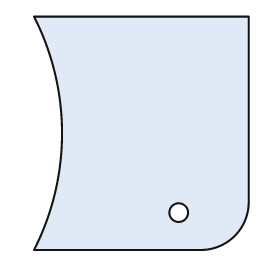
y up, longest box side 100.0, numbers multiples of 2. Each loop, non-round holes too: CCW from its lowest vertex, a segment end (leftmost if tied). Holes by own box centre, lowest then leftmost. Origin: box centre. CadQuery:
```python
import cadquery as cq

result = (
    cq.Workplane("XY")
    .moveTo(-46.0, -50.0)
    .lineTo(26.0, -50.0)
    .threePointArc((40.0, -44.0), (46.0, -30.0))
    .lineTo(46.0, 50.0)
    .lineTo(-46.0, 50.0)
    .threePointArc((-34.0, 0.0), (-46.0, -50.0))
    .close()
    .moveTo(16.0, -34.0)
    .circle(4.0)
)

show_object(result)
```